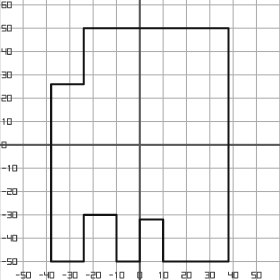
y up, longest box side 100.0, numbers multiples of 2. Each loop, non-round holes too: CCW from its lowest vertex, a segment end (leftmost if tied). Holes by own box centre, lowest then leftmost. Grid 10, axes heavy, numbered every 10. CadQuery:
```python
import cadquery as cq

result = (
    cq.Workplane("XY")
    .moveTo(-38.0, -50.0)
    .lineTo(-24.0, -50.0)
    .lineTo(-24.0, -30.0)
    .lineTo(-10.0, -30.0)
    .lineTo(-10.0, -50.0)
    .lineTo(0.0, -50.0)
    .lineTo(0.0, -32.0)
    .lineTo(10.0, -32.0)
    .lineTo(10.0, -50.0)
    .lineTo(38.0, -50.0)
    .lineTo(38.0, 50.0)
    .lineTo(-24.0, 50.0)
    .lineTo(-24.0, 26.0)
    .lineTo(-38.0, 26.0)
    .close()
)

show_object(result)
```